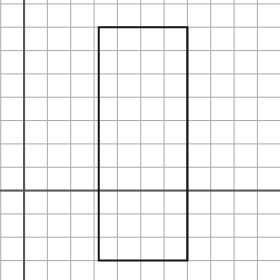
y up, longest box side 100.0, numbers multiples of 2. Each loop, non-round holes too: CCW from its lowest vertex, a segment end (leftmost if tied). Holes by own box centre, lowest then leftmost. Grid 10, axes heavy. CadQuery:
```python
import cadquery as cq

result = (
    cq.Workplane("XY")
    .moveTo(32.0, -30.0)
    .lineTo(70.0, -30.0)
    .lineTo(70.0, 70.0)
    .lineTo(32.0, 70.0)
    .close()
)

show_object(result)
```